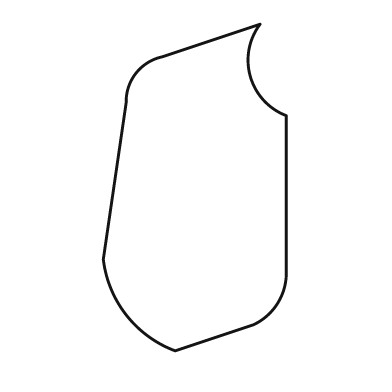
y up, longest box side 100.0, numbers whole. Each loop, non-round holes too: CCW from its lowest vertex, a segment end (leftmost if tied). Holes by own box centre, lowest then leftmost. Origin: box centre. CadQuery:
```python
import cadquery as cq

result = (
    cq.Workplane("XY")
    .moveTo(-6.0, -50.0)
    .lineTo(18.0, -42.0)
    .threePointArc((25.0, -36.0), (28.0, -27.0))
    .lineTo(28.0, 22.0)
    .threePointArc((17.0, 34.0), (20.0, 50.0))
    .lineTo(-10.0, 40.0)
    .threePointArc((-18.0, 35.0), (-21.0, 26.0))
    .lineTo(-28.0, -22.0)
    .threePointArc((-21.0, -39.0), (-6.0, -50.0))
    .close()
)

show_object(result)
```